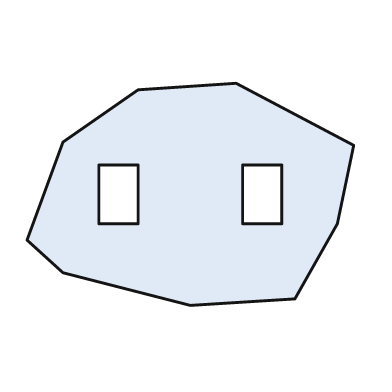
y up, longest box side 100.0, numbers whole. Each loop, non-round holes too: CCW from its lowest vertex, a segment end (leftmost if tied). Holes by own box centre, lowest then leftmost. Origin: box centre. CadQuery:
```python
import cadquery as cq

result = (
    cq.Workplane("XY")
    .moveTo(0.0, -34.0)
    .lineTo(32.0, -32.0)
    .lineTo(45.0, -9.0)
    .lineTo(50.0, 15.0)
    .lineTo(14.0, 34.0)
    .lineTo(-16.0, 32.0)
    .lineTo(-39.0, 16.0)
    .lineTo(-50.0, -14.0)
    .lineTo(-39.0, -24.0)
    .close()
    .moveTo(-28.0, -9.0)
    .lineTo(-16.0, -9.0)
    .lineTo(-16.0, 9.0)
    .lineTo(-28.0, 9.0)
    .close()
    .moveTo(16.0, -9.0)
    .lineTo(28.0, -9.0)
    .lineTo(28.0, 9.0)
    .lineTo(16.0, 9.0)
    .close()
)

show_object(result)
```